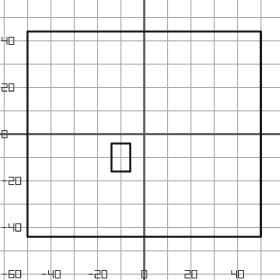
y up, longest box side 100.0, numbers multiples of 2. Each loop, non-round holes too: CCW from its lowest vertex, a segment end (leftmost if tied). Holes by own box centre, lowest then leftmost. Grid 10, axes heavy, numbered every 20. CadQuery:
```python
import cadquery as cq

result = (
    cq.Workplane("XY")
    .moveTo(-50.0, -44.0)
    .lineTo(50.0, -44.0)
    .lineTo(50.0, 44.0)
    .lineTo(-50.0, 44.0)
    .close()
    .moveTo(-14.0, -16.0)
    .lineTo(-6.0, -16.0)
    .lineTo(-6.0, -4.0)
    .lineTo(-14.0, -4.0)
    .close()
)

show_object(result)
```